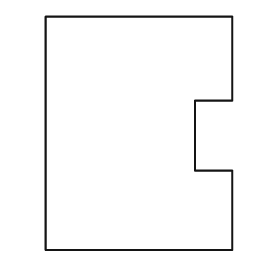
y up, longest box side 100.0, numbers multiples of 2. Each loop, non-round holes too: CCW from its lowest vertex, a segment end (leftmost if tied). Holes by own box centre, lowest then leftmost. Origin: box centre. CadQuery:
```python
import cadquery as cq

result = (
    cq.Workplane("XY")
    .moveTo(-40.0, -50.0)
    .lineTo(40.0, -50.0)
    .lineTo(40.0, -16.0)
    .lineTo(24.0, -16.0)
    .lineTo(24.0, 14.0)
    .lineTo(40.0, 14.0)
    .lineTo(40.0, 50.0)
    .lineTo(-40.0, 50.0)
    .close()
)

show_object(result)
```